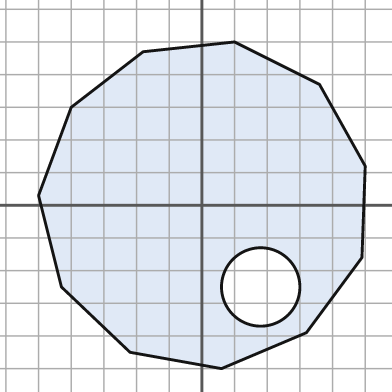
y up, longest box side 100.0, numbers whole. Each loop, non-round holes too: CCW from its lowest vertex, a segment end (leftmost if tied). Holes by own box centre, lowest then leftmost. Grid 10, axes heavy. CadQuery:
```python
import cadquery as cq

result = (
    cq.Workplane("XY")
    .moveTo(6.0, -50.0)
    .lineTo(32.0, -39.0)
    .lineTo(49.0, -16.0)
    .lineTo(50.0, 12.0)
    .lineTo(36.0, 37.0)
    .lineTo(10.0, 50.0)
    .lineTo(-18.0, 47.0)
    .lineTo(-40.0, 30.0)
    .lineTo(-50.0, 3.0)
    .lineTo(-43.0, -25.0)
    .lineTo(-22.0, -45.0)
    .close()
    .moveTo(18.0, -25.0)
    .circle(12.0)
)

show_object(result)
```